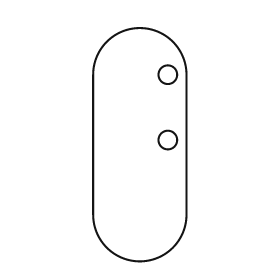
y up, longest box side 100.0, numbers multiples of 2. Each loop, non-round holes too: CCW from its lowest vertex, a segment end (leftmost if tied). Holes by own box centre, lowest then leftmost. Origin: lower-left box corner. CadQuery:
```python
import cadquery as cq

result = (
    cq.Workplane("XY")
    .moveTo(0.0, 20.0)
    .threePointArc((20.0, 0.0), (40.0, 20.0))
    .lineTo(40.0, 80.0)
    .threePointArc((20.0, 100.0), (0.0, 80.0))
    .close()
    .moveTo(32.0, 52.0)
    .circle(4.0)
    .moveTo(32.0, 80.0)
    .circle(4.0)
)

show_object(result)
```